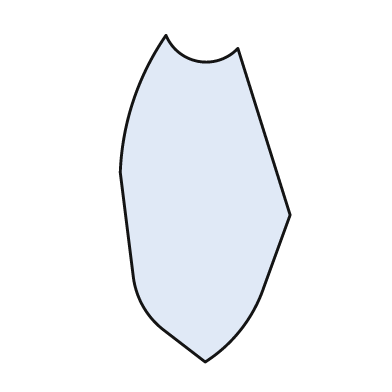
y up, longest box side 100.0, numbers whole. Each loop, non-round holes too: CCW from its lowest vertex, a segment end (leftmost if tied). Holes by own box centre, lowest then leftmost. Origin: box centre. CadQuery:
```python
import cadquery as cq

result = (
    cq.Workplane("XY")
    .moveTo(0.0, -50.0)
    .threePointArc((11.0, -40.0), (18.0, -27.0))
    .lineTo(26.0, -5.0)
    .lineTo(10.0, 46.0)
    .threePointArc((-2.0, 42.0), (-12.0, 50.0))
    .threePointArc((-22.0, 30.0), (-26.0, 8.0))
    .lineTo(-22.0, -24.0)
    .threePointArc((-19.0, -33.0), (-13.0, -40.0))
    .close()
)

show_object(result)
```